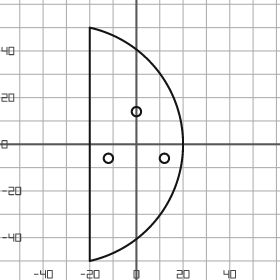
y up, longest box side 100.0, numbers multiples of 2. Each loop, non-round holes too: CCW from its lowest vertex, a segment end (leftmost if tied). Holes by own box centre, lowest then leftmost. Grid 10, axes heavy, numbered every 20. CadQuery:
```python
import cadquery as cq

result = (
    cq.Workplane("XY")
    .moveTo(-20.0, -50.0)
    .threePointArc((20.0, 0.0), (-20.0, 50.0))
    .close()
    .moveTo(-12.0, -6.0)
    .circle(2.0)
    .moveTo(12.0, -6.0)
    .circle(2.0)
    .moveTo(0.0, 14.0)
    .circle(2.0)
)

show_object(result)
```